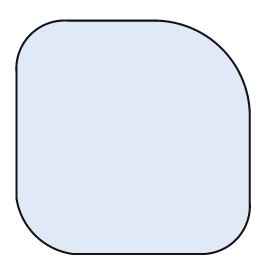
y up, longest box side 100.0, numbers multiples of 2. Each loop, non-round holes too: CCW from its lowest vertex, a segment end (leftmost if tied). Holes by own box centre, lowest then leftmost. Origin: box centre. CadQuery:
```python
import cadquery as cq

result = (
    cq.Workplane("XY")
    .moveTo(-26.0, -50.0)
    .lineTo(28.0, -50.0)
    .threePointArc((44.0, -44.0), (50.0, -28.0))
    .lineTo(50.0, 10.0)
    .threePointArc((38.0, 38.0), (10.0, 50.0))
    .lineTo(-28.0, 50.0)
    .threePointArc((-44.0, 44.0), (-50.0, 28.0))
    .lineTo(-50.0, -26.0)
    .threePointArc((-42.0, -42.0), (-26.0, -50.0))
    .close()
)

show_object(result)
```